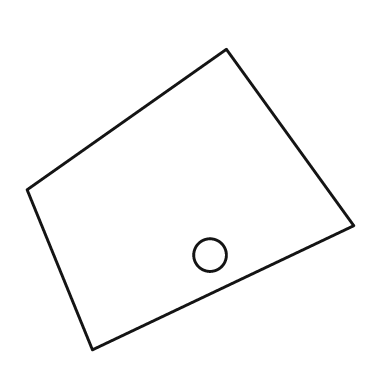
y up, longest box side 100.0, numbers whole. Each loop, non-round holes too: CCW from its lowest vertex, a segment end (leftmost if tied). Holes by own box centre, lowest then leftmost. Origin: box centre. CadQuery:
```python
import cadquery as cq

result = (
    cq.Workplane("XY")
    .moveTo(-30.0, -46.0)
    .lineTo(50.0, -8.0)
    .lineTo(11.0, 46.0)
    .lineTo(-50.0, 3.0)
    .close()
    .moveTo(6.0, -17.0)
    .circle(5.0)
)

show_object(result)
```